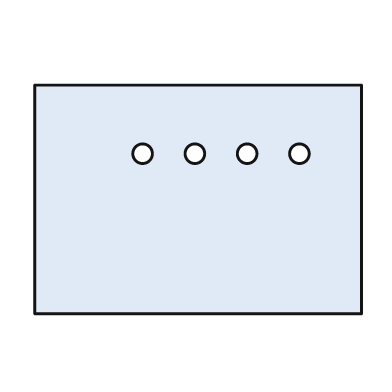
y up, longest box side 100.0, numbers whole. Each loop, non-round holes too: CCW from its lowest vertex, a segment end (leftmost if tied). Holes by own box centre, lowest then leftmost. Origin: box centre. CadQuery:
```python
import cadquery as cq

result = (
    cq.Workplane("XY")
    .moveTo(-50.0, -35.0)
    .lineTo(50.0, -35.0)
    .lineTo(50.0, 35.0)
    .lineTo(-50.0, 35.0)
    .close()
    .moveTo(-17.0, 14.0)
    .circle(3.0)
    .moveTo(-1.0, 14.0)
    .circle(3.0)
    .moveTo(15.0, 14.0)
    .circle(3.0)
    .moveTo(31.0, 14.0)
    .circle(3.0)
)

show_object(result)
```